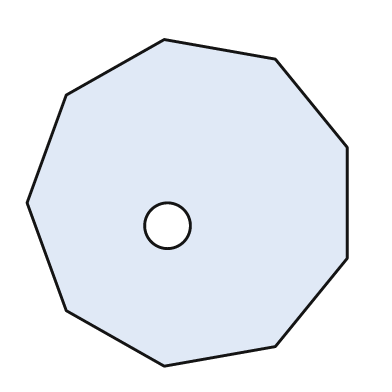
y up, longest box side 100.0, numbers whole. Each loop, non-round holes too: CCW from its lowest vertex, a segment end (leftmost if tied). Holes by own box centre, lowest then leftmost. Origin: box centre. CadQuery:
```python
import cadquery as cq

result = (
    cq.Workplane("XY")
    .moveTo(-7.0, -50.0)
    .lineTo(27.0, -44.0)
    .lineTo(49.0, -17.0)
    .lineTo(49.0, 17.0)
    .lineTo(27.0, 44.0)
    .lineTo(-7.0, 50.0)
    .lineTo(-37.0, 33.0)
    .lineTo(-49.0, 0.0)
    .lineTo(-37.0, -33.0)
    .close()
    .moveTo(-6.0, -7.0)
    .circle(7.0)
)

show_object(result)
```